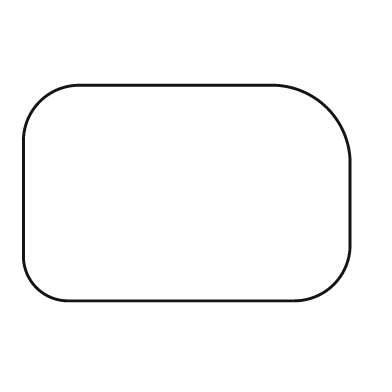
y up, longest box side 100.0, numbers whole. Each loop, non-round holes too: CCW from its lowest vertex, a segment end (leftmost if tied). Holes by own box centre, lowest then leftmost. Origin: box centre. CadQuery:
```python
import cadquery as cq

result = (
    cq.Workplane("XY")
    .moveTo(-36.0, -33.0)
    .lineTo(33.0, -33.0)
    .threePointArc((45.0, -28.0), (50.0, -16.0))
    .lineTo(50.0, 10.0)
    .threePointArc((43.0, 26.0), (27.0, 33.0))
    .lineTo(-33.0, 33.0)
    .threePointArc((-45.0, 28.0), (-50.0, 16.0))
    .lineTo(-50.0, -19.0)
    .threePointArc((-46.0, -29.0), (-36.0, -33.0))
    .close()
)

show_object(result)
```